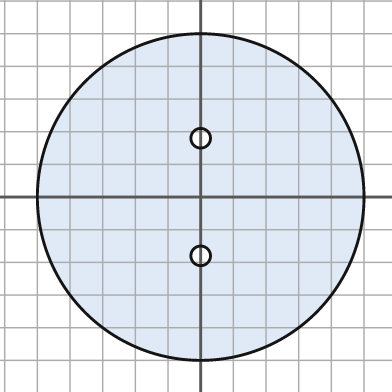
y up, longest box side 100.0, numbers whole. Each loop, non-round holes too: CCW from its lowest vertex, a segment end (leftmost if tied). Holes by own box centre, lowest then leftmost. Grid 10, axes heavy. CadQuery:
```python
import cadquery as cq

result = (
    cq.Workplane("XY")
    .moveTo(0.0, 0.0)
    .circle(50.0)
    .moveTo(0.0, -18.0)
    .circle(3.0)
    .moveTo(0.0, 18.0)
    .circle(3.0)
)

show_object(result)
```